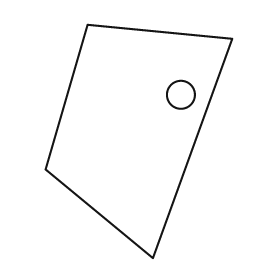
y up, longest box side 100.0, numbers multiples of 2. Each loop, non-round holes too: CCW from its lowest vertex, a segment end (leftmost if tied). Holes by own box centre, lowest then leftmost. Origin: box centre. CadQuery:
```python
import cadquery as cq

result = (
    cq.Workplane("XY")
    .moveTo(6.0, -50.0)
    .lineTo(40.0, 44.0)
    .lineTo(-22.0, 50.0)
    .lineTo(-40.0, -12.0)
    .close()
    .moveTo(18.0, 20.0)
    .circle(6.0)
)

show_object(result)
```